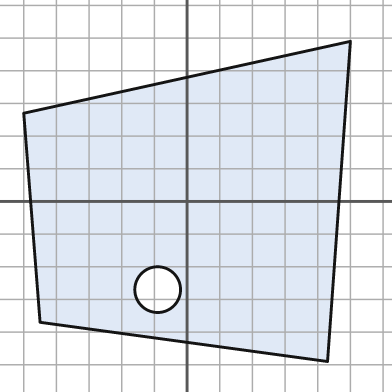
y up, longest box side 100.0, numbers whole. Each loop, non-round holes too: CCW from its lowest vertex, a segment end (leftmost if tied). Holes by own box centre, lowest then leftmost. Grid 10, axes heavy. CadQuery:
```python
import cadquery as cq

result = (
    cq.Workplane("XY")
    .moveTo(43.0, -49.0)
    .lineTo(50.0, 49.0)
    .lineTo(-50.0, 27.0)
    .lineTo(-45.0, -37.0)
    .close()
    .moveTo(-9.0, -27.0)
    .circle(7.0)
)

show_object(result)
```